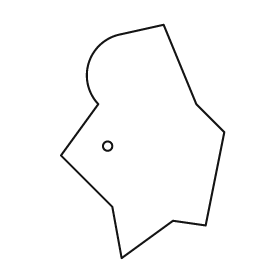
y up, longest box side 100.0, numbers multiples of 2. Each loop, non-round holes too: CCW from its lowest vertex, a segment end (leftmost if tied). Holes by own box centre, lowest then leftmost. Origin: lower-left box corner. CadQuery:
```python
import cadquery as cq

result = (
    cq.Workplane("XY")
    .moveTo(26.0, 0.0)
    .lineTo(48.0, 16.0)
    .lineTo(62.0, 14.0)
    .lineTo(70.0, 54.0)
    .lineTo(58.0, 66.0)
    .lineTo(44.0, 100.0)
    .lineTo(26.0, 96.0)
    .threePointArc((12.0, 84.0), (16.0, 66.0))
    .lineTo(0.0, 44.0)
    .lineTo(22.0, 22.0)
    .close()
    .moveTo(20.0, 48.0)
    .circle(2.0)
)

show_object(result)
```